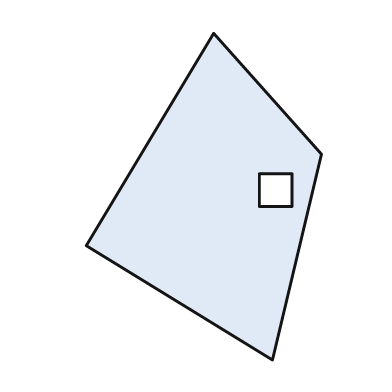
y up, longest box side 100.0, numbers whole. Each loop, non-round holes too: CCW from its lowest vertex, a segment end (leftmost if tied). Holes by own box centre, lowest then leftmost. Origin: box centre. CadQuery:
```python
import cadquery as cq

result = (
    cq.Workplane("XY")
    .moveTo(21.0, -50.0)
    .lineTo(36.0, 13.0)
    .lineTo(3.0, 50.0)
    .lineTo(-36.0, -15.0)
    .close()
    .moveTo(17.0, -3.0)
    .lineTo(27.0, -3.0)
    .lineTo(27.0, 7.0)
    .lineTo(17.0, 7.0)
    .close()
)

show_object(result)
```